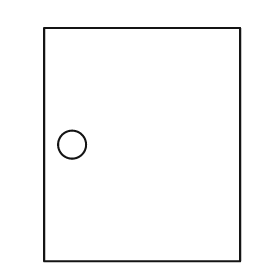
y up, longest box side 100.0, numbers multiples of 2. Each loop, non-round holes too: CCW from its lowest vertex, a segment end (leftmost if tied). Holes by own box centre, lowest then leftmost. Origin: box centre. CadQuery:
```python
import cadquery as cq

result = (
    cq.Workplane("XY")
    .moveTo(-42.0, -50.0)
    .lineTo(42.0, -50.0)
    .lineTo(42.0, 50.0)
    .lineTo(-42.0, 50.0)
    .close()
    .moveTo(-30.0, 0.0)
    .circle(6.0)
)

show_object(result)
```